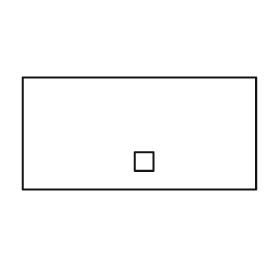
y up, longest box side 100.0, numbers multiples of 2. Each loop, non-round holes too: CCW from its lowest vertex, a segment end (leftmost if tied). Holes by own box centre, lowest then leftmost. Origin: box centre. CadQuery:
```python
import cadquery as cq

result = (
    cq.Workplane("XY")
    .moveTo(-50.0, -24.0)
    .lineTo(50.0, -24.0)
    .lineTo(50.0, 24.0)
    .lineTo(-50.0, 24.0)
    .close()
    .moveTo(-2.0, -16.0)
    .lineTo(6.0, -16.0)
    .lineTo(6.0, -8.0)
    .lineTo(-2.0, -8.0)
    .close()
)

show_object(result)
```